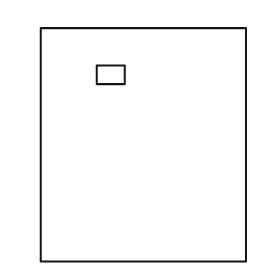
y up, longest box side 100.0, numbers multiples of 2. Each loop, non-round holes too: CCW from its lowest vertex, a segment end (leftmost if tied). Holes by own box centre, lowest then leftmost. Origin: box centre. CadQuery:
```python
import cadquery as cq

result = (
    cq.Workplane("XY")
    .moveTo(-44.0, -50.0)
    .lineTo(44.0, -50.0)
    .lineTo(44.0, 50.0)
    .lineTo(-44.0, 50.0)
    .close()
    .moveTo(-20.0, 26.0)
    .lineTo(-8.0, 26.0)
    .lineTo(-8.0, 34.0)
    .lineTo(-20.0, 34.0)
    .close()
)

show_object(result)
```